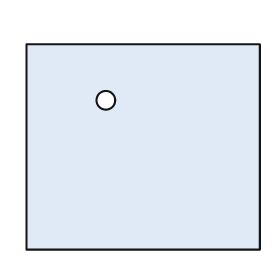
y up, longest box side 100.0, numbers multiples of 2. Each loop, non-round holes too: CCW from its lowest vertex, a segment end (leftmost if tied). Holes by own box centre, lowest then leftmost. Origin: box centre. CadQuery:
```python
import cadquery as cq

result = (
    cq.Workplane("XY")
    .moveTo(-50.0, -44.0)
    .lineTo(50.0, -44.0)
    .lineTo(50.0, 44.0)
    .lineTo(-50.0, 44.0)
    .close()
    .moveTo(-16.0, 20.0)
    .circle(4.0)
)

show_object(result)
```